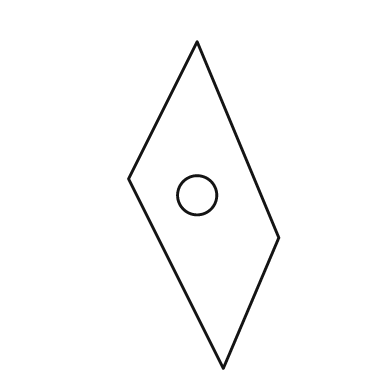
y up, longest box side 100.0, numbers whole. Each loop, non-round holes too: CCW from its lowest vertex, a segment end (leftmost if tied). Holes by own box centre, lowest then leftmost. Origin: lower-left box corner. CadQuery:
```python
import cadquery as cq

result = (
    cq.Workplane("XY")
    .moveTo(29.0, 0.0)
    .lineTo(46.0, 40.0)
    .lineTo(21.0, 100.0)
    .lineTo(0.0, 58.0)
    .close()
    .moveTo(21.0, 53.0)
    .circle(6.0)
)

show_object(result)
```